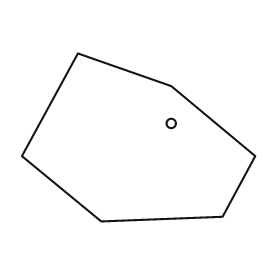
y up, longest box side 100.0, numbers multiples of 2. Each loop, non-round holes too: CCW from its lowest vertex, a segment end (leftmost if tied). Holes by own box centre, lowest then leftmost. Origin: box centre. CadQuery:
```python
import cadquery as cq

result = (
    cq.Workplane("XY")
    .moveTo(-16.0, -36.0)
    .lineTo(36.0, -34.0)
    .lineTo(50.0, -8.0)
    .lineTo(14.0, 22.0)
    .lineTo(-26.0, 36.0)
    .lineTo(-50.0, -8.0)
    .close()
    .moveTo(14.0, 6.0)
    .circle(2.0)
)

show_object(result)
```